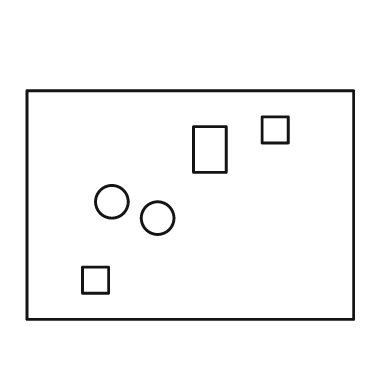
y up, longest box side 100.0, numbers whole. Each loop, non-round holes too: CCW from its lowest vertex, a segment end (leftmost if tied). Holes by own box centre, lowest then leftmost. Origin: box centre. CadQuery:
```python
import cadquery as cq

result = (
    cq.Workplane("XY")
    .moveTo(-50.0, -35.0)
    .lineTo(50.0, -35.0)
    .lineTo(50.0, 35.0)
    .lineTo(-50.0, 35.0)
    .close()
    .moveTo(-33.0, -27.0)
    .lineTo(-25.0, -27.0)
    .lineTo(-25.0, -19.0)
    .lineTo(-33.0, -19.0)
    .close()
    .moveTo(-10.0, -4.0)
    .circle(5.0)
    .moveTo(-24.0, 1.0)
    .circle(5.0)
    .moveTo(1.0, 10.0)
    .lineTo(11.0, 10.0)
    .lineTo(11.0, 24.0)
    .lineTo(1.0, 24.0)
    .close()
    .moveTo(22.0, 19.0)
    .lineTo(30.0, 19.0)
    .lineTo(30.0, 27.0)
    .lineTo(22.0, 27.0)
    .close()
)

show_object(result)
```